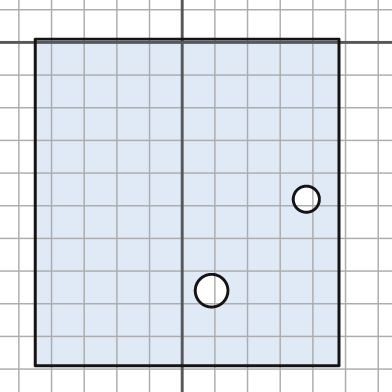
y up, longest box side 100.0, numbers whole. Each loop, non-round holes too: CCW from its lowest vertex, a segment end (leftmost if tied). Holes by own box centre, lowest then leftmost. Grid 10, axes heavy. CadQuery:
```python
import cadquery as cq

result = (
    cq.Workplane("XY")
    .moveTo(-45.0, -99.0)
    .lineTo(48.0, -99.0)
    .lineTo(48.0, 1.0)
    .lineTo(-45.0, 1.0)
    .close()
    .moveTo(9.0, -76.0)
    .circle(5.0)
    .moveTo(38.0, -48.0)
    .circle(4.0)
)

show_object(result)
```